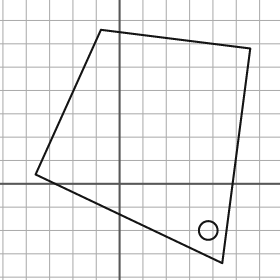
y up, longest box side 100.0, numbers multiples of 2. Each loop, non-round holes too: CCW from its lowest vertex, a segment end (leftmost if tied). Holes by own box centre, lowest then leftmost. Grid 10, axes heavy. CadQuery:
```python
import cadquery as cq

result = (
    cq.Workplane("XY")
    .moveTo(44.0, -34.0)
    .lineTo(56.0, 58.0)
    .lineTo(-8.0, 66.0)
    .lineTo(-36.0, 4.0)
    .close()
    .moveTo(38.0, -20.0)
    .circle(4.0)
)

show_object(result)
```